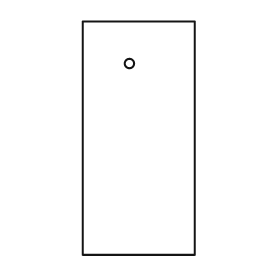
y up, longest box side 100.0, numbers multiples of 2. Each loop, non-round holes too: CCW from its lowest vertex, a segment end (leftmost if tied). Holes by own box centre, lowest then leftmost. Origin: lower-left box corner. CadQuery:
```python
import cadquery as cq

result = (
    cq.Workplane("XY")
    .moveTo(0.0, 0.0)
    .lineTo(48.0, 0.0)
    .lineTo(48.0, 100.0)
    .lineTo(0.0, 100.0)
    .close()
    .moveTo(20.0, 82.0)
    .circle(2.0)
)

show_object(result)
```